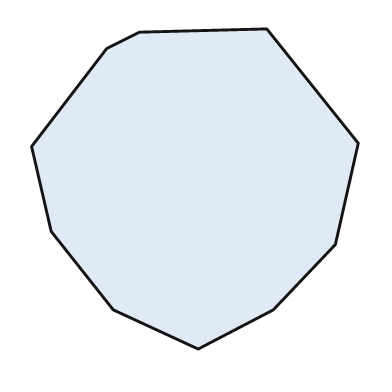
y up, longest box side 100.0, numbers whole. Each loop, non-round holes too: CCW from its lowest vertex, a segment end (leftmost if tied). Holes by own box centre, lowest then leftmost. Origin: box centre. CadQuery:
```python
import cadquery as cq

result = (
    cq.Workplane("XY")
    .moveTo(1.0, -49.0)
    .lineTo(24.0, -37.0)
    .lineTo(43.0, -17.0)
    .lineTo(50.0, 14.0)
    .lineTo(22.0, 49.0)
    .lineTo(-17.0, 48.0)
    .lineTo(-27.0, 43.0)
    .lineTo(-50.0, 13.0)
    .lineTo(-44.0, -13.0)
    .lineTo(-25.0, -37.0)
    .close()
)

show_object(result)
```